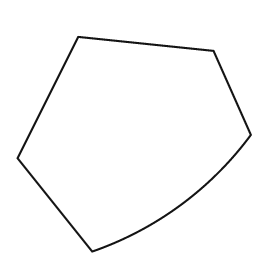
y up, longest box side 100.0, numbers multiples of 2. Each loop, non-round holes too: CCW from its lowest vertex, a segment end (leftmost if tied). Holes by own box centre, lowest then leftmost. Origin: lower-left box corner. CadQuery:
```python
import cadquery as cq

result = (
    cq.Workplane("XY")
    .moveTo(32.0, 0.0)
    .threePointArc((70.0, 20.0), (100.0, 50.0))
    .lineTo(84.0, 86.0)
    .lineTo(26.0, 92.0)
    .lineTo(0.0, 40.0)
    .close()
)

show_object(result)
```